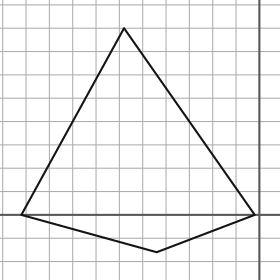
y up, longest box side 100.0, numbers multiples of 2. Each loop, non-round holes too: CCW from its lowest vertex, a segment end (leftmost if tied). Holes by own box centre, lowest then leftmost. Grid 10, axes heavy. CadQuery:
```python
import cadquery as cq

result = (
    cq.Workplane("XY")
    .moveTo(-44.0, -16.0)
    .lineTo(-2.0, 0.0)
    .lineTo(-58.0, 80.0)
    .lineTo(-102.0, 0.0)
    .close()
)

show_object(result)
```